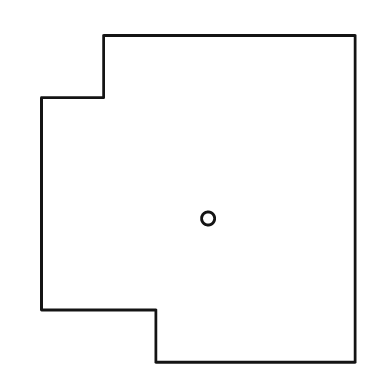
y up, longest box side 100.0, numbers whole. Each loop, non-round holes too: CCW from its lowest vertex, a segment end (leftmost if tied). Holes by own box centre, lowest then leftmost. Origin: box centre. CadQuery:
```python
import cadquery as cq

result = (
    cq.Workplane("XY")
    .moveTo(-13.0, -50.0)
    .lineTo(48.0, -50.0)
    .lineTo(48.0, 50.0)
    .lineTo(-29.0, 50.0)
    .lineTo(-29.0, 31.0)
    .lineTo(-48.0, 31.0)
    .lineTo(-48.0, -34.0)
    .lineTo(-13.0, -34.0)
    .close()
    .moveTo(3.0, -6.0)
    .circle(2.0)
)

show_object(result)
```